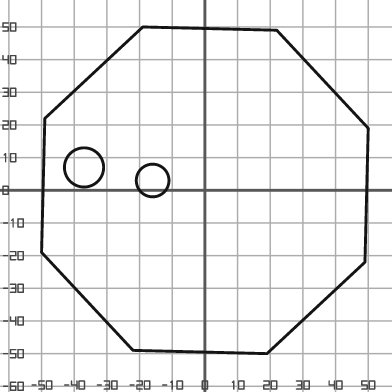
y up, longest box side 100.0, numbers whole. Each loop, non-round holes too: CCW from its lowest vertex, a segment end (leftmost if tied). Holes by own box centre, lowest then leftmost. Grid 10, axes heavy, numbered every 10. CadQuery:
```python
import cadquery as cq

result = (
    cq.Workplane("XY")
    .moveTo(19.0, -50.0)
    .lineTo(49.0, -22.0)
    .lineTo(50.0, 19.0)
    .lineTo(22.0, 49.0)
    .lineTo(-19.0, 50.0)
    .lineTo(-49.0, 22.0)
    .lineTo(-50.0, -19.0)
    .lineTo(-22.0, -49.0)
    .close()
    .moveTo(-16.0, 3.0)
    .circle(5.0)
    .moveTo(-37.0, 7.0)
    .circle(6.0)
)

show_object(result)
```